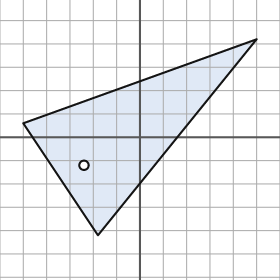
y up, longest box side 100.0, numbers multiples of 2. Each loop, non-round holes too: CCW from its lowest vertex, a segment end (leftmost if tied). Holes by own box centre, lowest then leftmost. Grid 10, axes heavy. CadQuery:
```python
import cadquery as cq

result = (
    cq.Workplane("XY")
    .moveTo(-18.0, -42.0)
    .lineTo(50.0, 42.0)
    .lineTo(-50.0, 6.0)
    .close()
    .moveTo(-24.0, -12.0)
    .circle(2.0)
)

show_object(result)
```